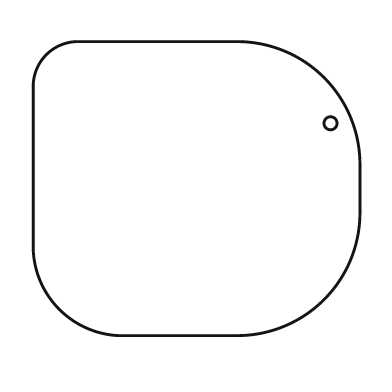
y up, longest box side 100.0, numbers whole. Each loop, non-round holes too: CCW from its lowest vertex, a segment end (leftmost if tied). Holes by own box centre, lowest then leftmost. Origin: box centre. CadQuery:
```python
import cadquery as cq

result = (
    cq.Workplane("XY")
    .moveTo(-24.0, -45.0)
    .lineTo(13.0, -45.0)
    .threePointArc((39.0, -34.0), (50.0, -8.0))
    .lineTo(50.0, 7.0)
    .threePointArc((39.0, 34.0), (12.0, 45.0))
    .lineTo(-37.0, 45.0)
    .threePointArc((-46.0, 41.0), (-50.0, 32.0))
    .lineTo(-50.0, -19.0)
    .threePointArc((-42.0, -37.0), (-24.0, -45.0))
    .close()
    .moveTo(41.0, 20.0)
    .circle(2.0)
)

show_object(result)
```